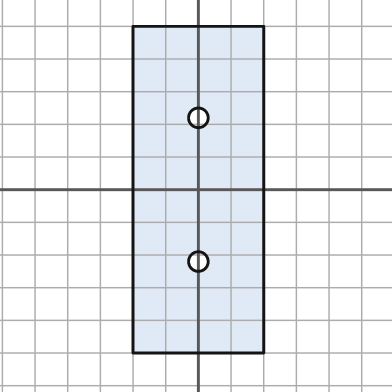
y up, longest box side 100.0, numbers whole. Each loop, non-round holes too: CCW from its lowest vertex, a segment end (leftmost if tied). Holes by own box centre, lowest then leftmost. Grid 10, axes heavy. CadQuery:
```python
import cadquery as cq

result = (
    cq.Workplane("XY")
    .moveTo(-20.0, -50.0)
    .lineTo(20.0, -50.0)
    .lineTo(20.0, 50.0)
    .lineTo(-20.0, 50.0)
    .close()
    .moveTo(0.0, -22.0)
    .circle(3.0)
    .moveTo(0.0, 22.0)
    .circle(3.0)
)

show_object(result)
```